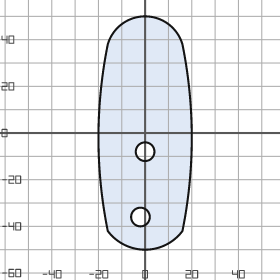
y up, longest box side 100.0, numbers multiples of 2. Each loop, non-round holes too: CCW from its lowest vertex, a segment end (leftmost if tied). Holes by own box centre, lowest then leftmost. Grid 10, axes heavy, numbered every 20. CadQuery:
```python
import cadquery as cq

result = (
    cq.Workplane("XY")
    .moveTo(-16.0, -42.0)
    .threePointArc((0.0, -50.0), (16.0, -42.0))
    .threePointArc((20.0, -2.0), (16.0, 38.0))
    .threePointArc((0.0, 50.0), (-16.0, 38.0))
    .threePointArc((-20.0, -2.0), (-16.0, -42.0))
    .close()
    .moveTo(-2.0, -36.0)
    .circle(4.0)
    .moveTo(0.0, -8.0)
    .circle(4.0)
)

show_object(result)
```